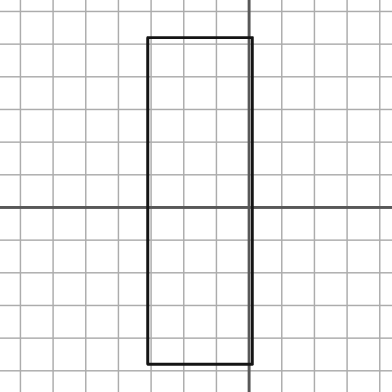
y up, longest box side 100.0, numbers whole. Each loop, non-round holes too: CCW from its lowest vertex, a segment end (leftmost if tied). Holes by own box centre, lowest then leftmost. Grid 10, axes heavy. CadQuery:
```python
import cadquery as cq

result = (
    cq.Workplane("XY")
    .moveTo(-31.0, -48.0)
    .lineTo(1.0, -48.0)
    .lineTo(1.0, 52.0)
    .lineTo(-31.0, 52.0)
    .close()
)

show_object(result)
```